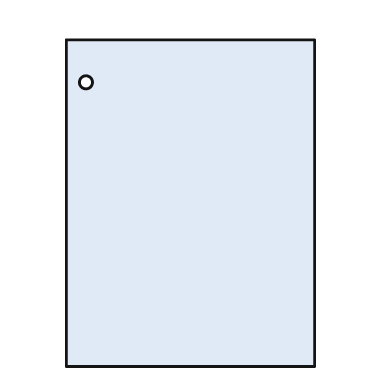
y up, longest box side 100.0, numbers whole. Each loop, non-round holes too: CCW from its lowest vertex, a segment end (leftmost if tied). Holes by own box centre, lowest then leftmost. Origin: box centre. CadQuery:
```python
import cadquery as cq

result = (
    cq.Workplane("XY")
    .moveTo(-38.0, -50.0)
    .lineTo(38.0, -50.0)
    .lineTo(38.0, 50.0)
    .lineTo(-38.0, 50.0)
    .close()
    .moveTo(-32.0, 37.0)
    .circle(2.0)
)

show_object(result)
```